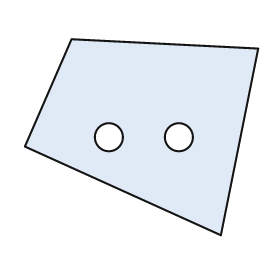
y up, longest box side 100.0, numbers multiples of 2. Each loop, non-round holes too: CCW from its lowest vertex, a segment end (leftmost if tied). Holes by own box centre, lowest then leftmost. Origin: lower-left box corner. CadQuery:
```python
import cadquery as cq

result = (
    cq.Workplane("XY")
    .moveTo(84.0, 0.0)
    .lineTo(100.0, 80.0)
    .lineTo(20.0, 84.0)
    .lineTo(0.0, 38.0)
    .close()
    .moveTo(36.0, 42.0)
    .circle(6.0)
    .moveTo(66.0, 42.0)
    .circle(6.0)
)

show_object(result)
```